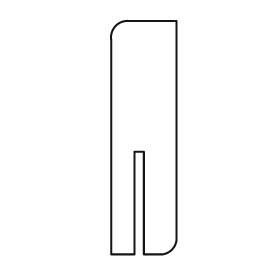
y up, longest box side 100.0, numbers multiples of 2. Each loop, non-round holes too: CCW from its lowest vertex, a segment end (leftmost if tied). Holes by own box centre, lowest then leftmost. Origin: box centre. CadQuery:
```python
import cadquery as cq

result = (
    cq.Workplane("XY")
    .moveTo(-14.0, -50.0)
    .lineTo(-4.0, -50.0)
    .lineTo(-4.0, -6.0)
    .lineTo(0.0, -6.0)
    .lineTo(0.0, -50.0)
    .lineTo(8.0, -50.0)
    .threePointArc((12.0, -48.0), (14.0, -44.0))
    .lineTo(14.0, 50.0)
    .lineTo(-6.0, 50.0)
    .threePointArc((-12.0, 48.0), (-14.0, 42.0))
    .close()
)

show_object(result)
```